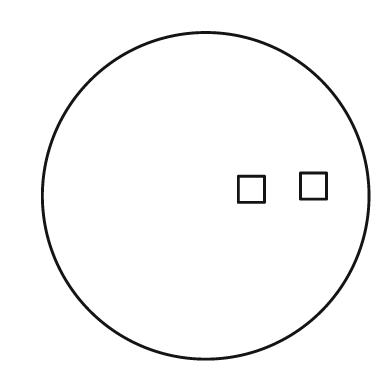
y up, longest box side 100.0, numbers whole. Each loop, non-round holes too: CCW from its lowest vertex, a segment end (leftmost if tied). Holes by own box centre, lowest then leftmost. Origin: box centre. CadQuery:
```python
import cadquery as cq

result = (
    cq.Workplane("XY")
    .moveTo(0.0, 0.0)
    .circle(50.0)
    .moveTo(10.0, -2.0)
    .lineTo(18.0, -2.0)
    .lineTo(18.0, 6.0)
    .lineTo(10.0, 6.0)
    .close()
    .moveTo(29.0, -1.0)
    .lineTo(37.0, -1.0)
    .lineTo(37.0, 7.0)
    .lineTo(29.0, 7.0)
    .close()
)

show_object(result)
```